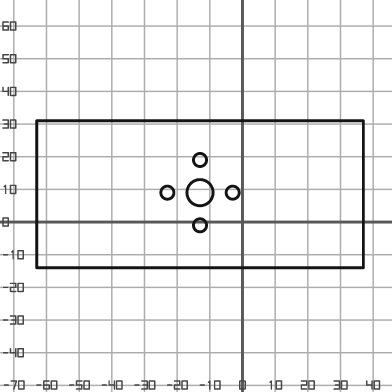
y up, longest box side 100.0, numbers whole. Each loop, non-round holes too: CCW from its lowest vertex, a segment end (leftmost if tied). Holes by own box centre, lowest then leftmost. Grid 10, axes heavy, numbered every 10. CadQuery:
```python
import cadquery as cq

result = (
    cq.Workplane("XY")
    .moveTo(-63.0, -14.0)
    .lineTo(37.0, -14.0)
    .lineTo(37.0, 31.0)
    .lineTo(-63.0, 31.0)
    .close()
    .moveTo(-13.0, -1.0)
    .circle(2.0)
    .moveTo(-23.0, 9.0)
    .circle(2.0)
    .moveTo(-13.0, 9.0)
    .circle(4.0)
    .moveTo(-3.0, 9.0)
    .circle(2.0)
    .moveTo(-13.0, 19.0)
    .circle(2.0)
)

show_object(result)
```